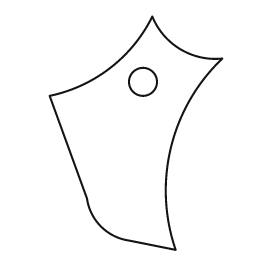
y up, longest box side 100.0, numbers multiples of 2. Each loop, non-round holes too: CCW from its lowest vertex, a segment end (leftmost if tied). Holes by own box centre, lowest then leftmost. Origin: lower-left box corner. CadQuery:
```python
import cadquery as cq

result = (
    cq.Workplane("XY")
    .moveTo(54.0, 0.0)
    .threePointArc((52.0, 44.0), (74.0, 82.0))
    .threePointArc((56.0, 86.0), (44.0, 100.0))
    .threePointArc((26.0, 78.0), (0.0, 66.0))
    .lineTo(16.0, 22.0)
    .threePointArc((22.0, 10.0), (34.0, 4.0))
    .close()
    .moveTo(40.0, 72.0)
    .circle(6.0)
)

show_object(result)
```